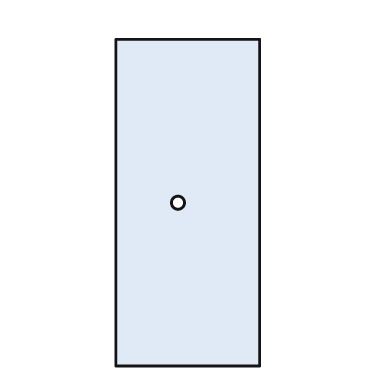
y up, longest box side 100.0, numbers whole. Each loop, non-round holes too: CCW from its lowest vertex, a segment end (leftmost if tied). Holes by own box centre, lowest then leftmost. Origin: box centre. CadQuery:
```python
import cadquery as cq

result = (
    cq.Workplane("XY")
    .moveTo(-22.0, -50.0)
    .lineTo(22.0, -50.0)
    .lineTo(22.0, 50.0)
    .lineTo(-22.0, 50.0)
    .close()
    .moveTo(-3.0, 0.0)
    .circle(2.0)
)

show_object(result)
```